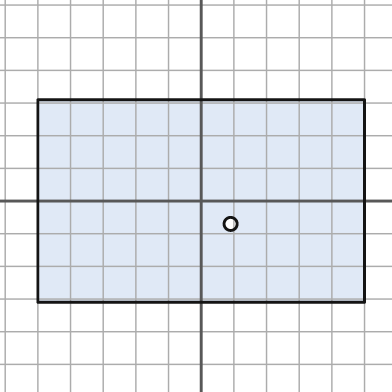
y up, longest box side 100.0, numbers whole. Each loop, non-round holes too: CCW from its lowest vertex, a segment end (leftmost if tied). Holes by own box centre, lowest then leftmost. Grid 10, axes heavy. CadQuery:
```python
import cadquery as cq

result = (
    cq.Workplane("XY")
    .moveTo(-50.0, -31.0)
    .lineTo(50.0, -31.0)
    .lineTo(50.0, 31.0)
    .lineTo(-50.0, 31.0)
    .close()
    .moveTo(9.0, -7.0)
    .circle(2.0)
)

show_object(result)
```